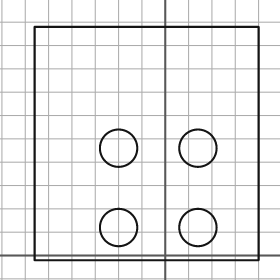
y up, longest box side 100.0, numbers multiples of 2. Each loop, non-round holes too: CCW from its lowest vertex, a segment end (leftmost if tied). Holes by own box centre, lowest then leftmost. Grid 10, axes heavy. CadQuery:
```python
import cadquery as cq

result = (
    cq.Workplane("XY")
    .moveTo(-56.0, -2.0)
    .lineTo(40.0, -2.0)
    .lineTo(40.0, 98.0)
    .lineTo(-56.0, 98.0)
    .close()
    .moveTo(-20.0, 12.0)
    .circle(8.0)
    .moveTo(14.0, 12.0)
    .circle(8.0)
    .moveTo(-20.0, 46.0)
    .circle(8.0)
    .moveTo(14.0, 46.0)
    .circle(8.0)
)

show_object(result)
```